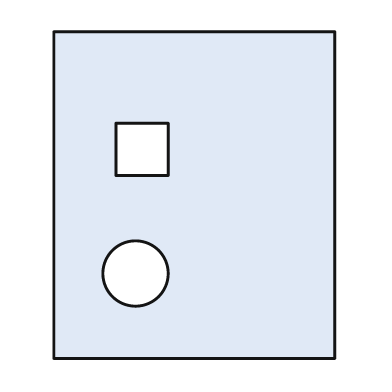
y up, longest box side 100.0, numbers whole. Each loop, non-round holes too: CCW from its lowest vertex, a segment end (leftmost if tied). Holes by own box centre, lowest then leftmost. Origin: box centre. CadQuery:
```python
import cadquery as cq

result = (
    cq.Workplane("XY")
    .moveTo(-43.0, -50.0)
    .lineTo(43.0, -50.0)
    .lineTo(43.0, 50.0)
    .lineTo(-43.0, 50.0)
    .close()
    .moveTo(-18.0, -24.0)
    .circle(10.0)
    .moveTo(-24.0, 6.0)
    .lineTo(-8.0, 6.0)
    .lineTo(-8.0, 22.0)
    .lineTo(-24.0, 22.0)
    .close()
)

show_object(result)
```